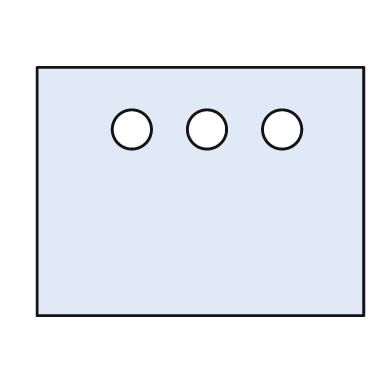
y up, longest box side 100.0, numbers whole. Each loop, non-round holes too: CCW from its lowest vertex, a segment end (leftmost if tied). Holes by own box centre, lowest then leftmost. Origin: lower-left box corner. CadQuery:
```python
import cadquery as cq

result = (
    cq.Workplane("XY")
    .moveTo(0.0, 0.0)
    .lineTo(100.0, 0.0)
    .lineTo(100.0, 76.0)
    .lineTo(0.0, 76.0)
    .close()
    .moveTo(29.0, 57.0)
    .circle(6.0)
    .moveTo(52.0, 57.0)
    .circle(6.0)
    .moveTo(75.0, 57.0)
    .circle(6.0)
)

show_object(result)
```